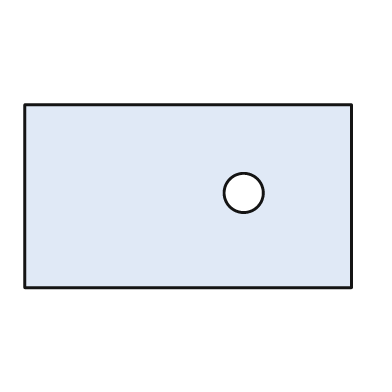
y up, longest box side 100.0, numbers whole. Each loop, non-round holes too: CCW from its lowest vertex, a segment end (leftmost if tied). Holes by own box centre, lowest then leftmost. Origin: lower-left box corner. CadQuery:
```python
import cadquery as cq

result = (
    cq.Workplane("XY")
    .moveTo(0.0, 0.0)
    .lineTo(100.0, 0.0)
    .lineTo(100.0, 56.0)
    .lineTo(0.0, 56.0)
    .close()
    .moveTo(67.0, 29.0)
    .circle(6.0)
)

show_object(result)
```